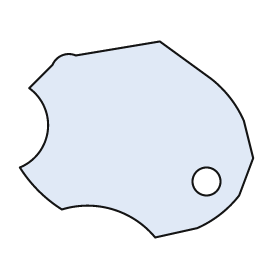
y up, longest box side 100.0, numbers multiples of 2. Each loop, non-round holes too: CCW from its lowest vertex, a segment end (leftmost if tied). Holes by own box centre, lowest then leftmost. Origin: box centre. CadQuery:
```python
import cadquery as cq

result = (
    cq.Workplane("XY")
    .moveTo(8.0, -42.0)
    .lineTo(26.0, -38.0)
    .threePointArc((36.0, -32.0), (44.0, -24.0))
    .lineTo(50.0, -8.0)
    .lineTo(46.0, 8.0)
    .threePointArc((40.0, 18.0), (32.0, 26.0))
    .lineTo(10.0, 42.0)
    .lineTo(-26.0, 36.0)
    .threePointArc((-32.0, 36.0), (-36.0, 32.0))
    .lineTo(-46.0, 22.0)
    .threePointArc((-38.0, 4.0), (-50.0, -12.0))
    .threePointArc((-42.0, -22.0), (-32.0, -30.0))
    .threePointArc((-10.0, -30.0), (8.0, -42.0))
    .close()
    .moveTo(30.0, -18.0)
    .circle(6.0)
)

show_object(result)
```